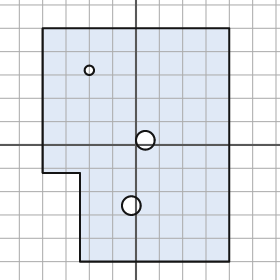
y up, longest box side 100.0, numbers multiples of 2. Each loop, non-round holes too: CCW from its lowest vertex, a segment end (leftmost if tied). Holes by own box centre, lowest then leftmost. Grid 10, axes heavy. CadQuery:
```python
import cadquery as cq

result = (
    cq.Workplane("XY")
    .moveTo(-24.0, -50.0)
    .lineTo(40.0, -50.0)
    .lineTo(40.0, 50.0)
    .lineTo(-40.0, 50.0)
    .lineTo(-40.0, -12.0)
    .lineTo(-24.0, -12.0)
    .close()
    .moveTo(-2.0, -26.0)
    .circle(4.0)
    .moveTo(4.0, 2.0)
    .circle(4.0)
    .moveTo(-20.0, 32.0)
    .circle(2.0)
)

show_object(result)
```